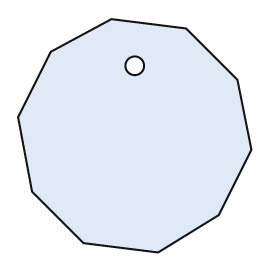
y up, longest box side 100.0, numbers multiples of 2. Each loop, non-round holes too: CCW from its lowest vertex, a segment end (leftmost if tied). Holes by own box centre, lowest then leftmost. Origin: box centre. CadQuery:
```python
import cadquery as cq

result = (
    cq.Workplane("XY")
    .moveTo(10.0, -50.0)
    .lineTo(36.0, -34.0)
    .lineTo(50.0, -6.0)
    .lineTo(44.0, 24.0)
    .lineTo(22.0, 46.0)
    .lineTo(-10.0, 50.0)
    .lineTo(-36.0, 36.0)
    .lineTo(-50.0, 8.0)
    .lineTo(-44.0, -24.0)
    .lineTo(-22.0, -46.0)
    .close()
    .moveTo(0.0, 30.0)
    .circle(4.0)
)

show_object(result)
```